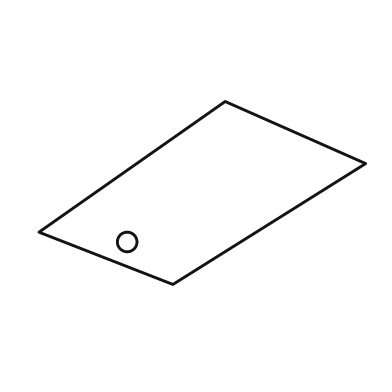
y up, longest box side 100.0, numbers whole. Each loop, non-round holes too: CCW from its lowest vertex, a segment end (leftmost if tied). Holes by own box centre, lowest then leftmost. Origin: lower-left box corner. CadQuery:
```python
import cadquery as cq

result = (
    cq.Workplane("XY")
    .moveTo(41.0, 0.0)
    .lineTo(100.0, 37.0)
    .lineTo(57.0, 56.0)
    .lineTo(0.0, 16.0)
    .close()
    .moveTo(27.0, 13.0)
    .circle(3.0)
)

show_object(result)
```